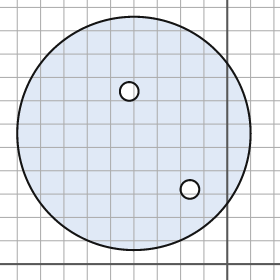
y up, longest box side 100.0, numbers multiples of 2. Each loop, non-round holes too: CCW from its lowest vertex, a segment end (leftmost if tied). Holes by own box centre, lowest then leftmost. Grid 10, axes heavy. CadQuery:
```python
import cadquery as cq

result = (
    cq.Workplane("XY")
    .moveTo(-40.0, 56.0)
    .circle(50.0)
    .moveTo(-16.0, 32.0)
    .circle(4.0)
    .moveTo(-42.0, 74.0)
    .circle(4.0)
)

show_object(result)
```